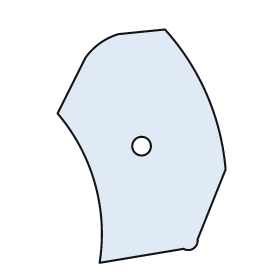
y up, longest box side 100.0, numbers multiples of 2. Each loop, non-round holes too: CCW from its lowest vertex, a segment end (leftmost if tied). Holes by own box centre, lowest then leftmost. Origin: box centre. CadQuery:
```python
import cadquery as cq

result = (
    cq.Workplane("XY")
    .moveTo(-18.0, -50.0)
    .lineTo(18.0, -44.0)
    .threePointArc((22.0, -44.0), (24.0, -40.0))
    .lineTo(36.0, -10.0)
    .threePointArc((28.0, 22.0), (10.0, 50.0))
    .lineTo(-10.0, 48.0)
    .threePointArc((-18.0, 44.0), (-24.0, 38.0))
    .lineTo(-36.0, 14.0)
    .threePointArc((-20.0, -16.0), (-18.0, -50.0))
    .close()
    .moveTo(0.0, 0.0)
    .circle(4.0)
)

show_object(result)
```